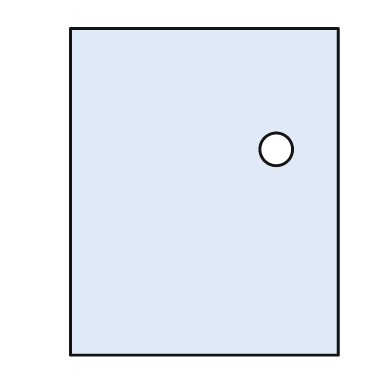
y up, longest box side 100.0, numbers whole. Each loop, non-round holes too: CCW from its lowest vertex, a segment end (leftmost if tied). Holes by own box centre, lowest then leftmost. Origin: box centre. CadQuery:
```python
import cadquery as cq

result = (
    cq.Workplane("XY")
    .moveTo(-41.0, -50.0)
    .lineTo(41.0, -50.0)
    .lineTo(41.0, 50.0)
    .lineTo(-41.0, 50.0)
    .close()
    .moveTo(22.0, 13.0)
    .circle(5.0)
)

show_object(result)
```